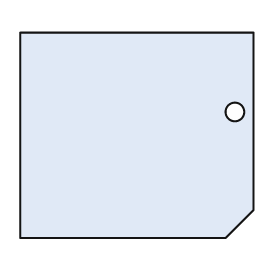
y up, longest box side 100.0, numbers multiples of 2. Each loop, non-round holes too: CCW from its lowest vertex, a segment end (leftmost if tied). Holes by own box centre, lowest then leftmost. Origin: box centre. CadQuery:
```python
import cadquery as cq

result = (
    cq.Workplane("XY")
    .moveTo(-50.0, -44.0)
    .lineTo(38.0, -44.0)
    .lineTo(50.0, -32.0)
    .lineTo(50.0, 44.0)
    .lineTo(-50.0, 44.0)
    .close()
    .moveTo(42.0, 10.0)
    .circle(4.0)
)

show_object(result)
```